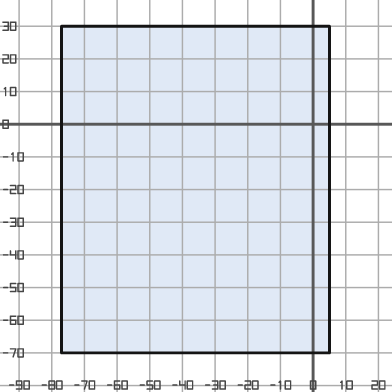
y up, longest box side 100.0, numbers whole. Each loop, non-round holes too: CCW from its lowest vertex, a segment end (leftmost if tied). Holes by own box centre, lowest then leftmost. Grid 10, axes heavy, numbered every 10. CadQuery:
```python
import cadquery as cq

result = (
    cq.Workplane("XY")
    .moveTo(-77.0, -70.0)
    .lineTo(5.0, -70.0)
    .lineTo(5.0, 30.0)
    .lineTo(-77.0, 30.0)
    .close()
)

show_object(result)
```